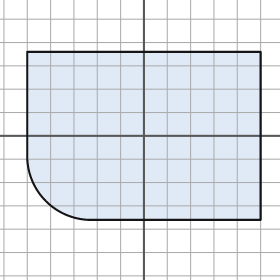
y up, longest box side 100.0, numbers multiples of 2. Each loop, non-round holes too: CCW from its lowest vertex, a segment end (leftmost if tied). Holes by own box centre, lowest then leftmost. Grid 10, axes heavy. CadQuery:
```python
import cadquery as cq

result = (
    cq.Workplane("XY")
    .moveTo(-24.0, -36.0)
    .lineTo(50.0, -36.0)
    .lineTo(50.0, 36.0)
    .lineTo(-50.0, 36.0)
    .lineTo(-50.0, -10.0)
    .threePointArc((-42.0, -28.0), (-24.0, -36.0))
    .close()
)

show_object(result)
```